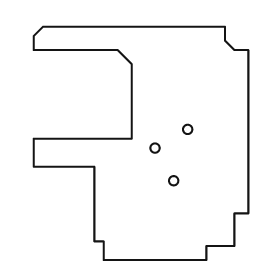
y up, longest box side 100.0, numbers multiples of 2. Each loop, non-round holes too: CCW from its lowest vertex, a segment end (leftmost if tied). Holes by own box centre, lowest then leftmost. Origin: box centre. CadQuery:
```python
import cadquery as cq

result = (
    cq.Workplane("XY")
    .moveTo(-16.0, -50.0)
    .lineTo(28.0, -50.0)
    .lineTo(28.0, -44.0)
    .lineTo(40.0, -44.0)
    .lineTo(40.0, -30.0)
    .lineTo(46.0, -30.0)
    .lineTo(46.0, 40.0)
    .lineTo(40.0, 40.0)
    .lineTo(36.0, 44.0)
    .lineTo(36.0, 50.0)
    .lineTo(-42.0, 50.0)
    .lineTo(-46.0, 46.0)
    .lineTo(-46.0, 40.0)
    .lineTo(-10.0, 40.0)
    .lineTo(-4.0, 34.0)
    .lineTo(-4.0, 2.0)
    .lineTo(-46.0, 2.0)
    .lineTo(-46.0, -10.0)
    .lineTo(-20.0, -10.0)
    .lineTo(-20.0, -42.0)
    .lineTo(-16.0, -42.0)
    .close()
    .moveTo(14.0, -16.0)
    .circle(2.0)
    .moveTo(6.0, -2.0)
    .circle(2.0)
    .moveTo(20.0, 6.0)
    .circle(2.0)
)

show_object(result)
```